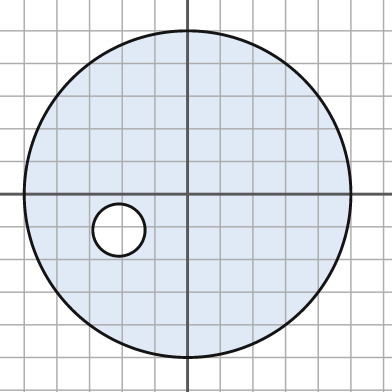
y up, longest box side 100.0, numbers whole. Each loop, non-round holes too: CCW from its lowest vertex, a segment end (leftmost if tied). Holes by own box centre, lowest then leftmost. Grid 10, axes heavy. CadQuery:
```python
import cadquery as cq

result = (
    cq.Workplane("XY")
    .moveTo(0.0, 0.0)
    .circle(50.0)
    .moveTo(-21.0, -11.0)
    .circle(8.0)
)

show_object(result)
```